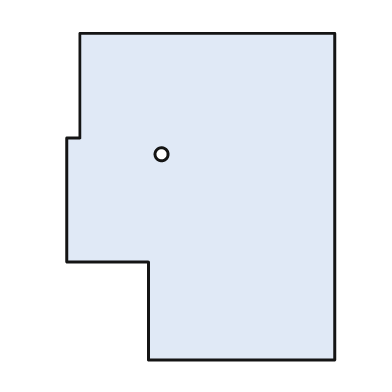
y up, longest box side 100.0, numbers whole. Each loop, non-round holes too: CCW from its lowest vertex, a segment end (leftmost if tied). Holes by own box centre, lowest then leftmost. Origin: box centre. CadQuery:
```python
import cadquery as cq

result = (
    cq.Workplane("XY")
    .moveTo(-16.0, -50.0)
    .lineTo(41.0, -50.0)
    .lineTo(41.0, 50.0)
    .lineTo(-37.0, 50.0)
    .lineTo(-37.0, 18.0)
    .lineTo(-41.0, 18.0)
    .lineTo(-41.0, -20.0)
    .lineTo(-16.0, -20.0)
    .close()
    .moveTo(-12.0, 13.0)
    .circle(2.0)
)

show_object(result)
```